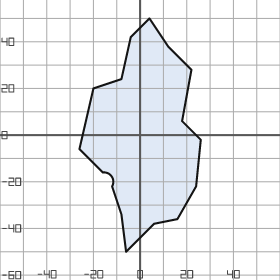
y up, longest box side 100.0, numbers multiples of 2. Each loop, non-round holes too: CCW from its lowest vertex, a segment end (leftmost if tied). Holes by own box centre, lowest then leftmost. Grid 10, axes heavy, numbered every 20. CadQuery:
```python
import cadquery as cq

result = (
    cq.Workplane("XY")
    .moveTo(-6.0, -50.0)
    .lineTo(6.0, -38.0)
    .lineTo(16.0, -36.0)
    .lineTo(24.0, -22.0)
    .lineTo(26.0, -2.0)
    .lineTo(18.0, 6.0)
    .lineTo(22.0, 28.0)
    .lineTo(12.0, 38.0)
    .lineTo(4.0, 50.0)
    .lineTo(-4.0, 42.0)
    .lineTo(-8.0, 24.0)
    .lineTo(-20.0, 20.0)
    .lineTo(-26.0, -6.0)
    .lineTo(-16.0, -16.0)
    .threePointArc((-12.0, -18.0), (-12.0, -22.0))
    .lineTo(-8.0, -34.0)
    .close()
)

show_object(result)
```